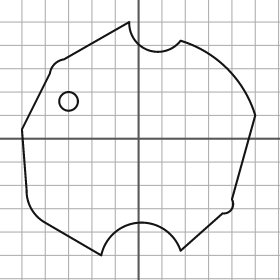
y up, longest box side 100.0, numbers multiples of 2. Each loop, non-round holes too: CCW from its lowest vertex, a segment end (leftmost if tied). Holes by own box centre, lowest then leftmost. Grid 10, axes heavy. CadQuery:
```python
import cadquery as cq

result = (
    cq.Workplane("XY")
    .moveTo(-16.0, -50.0)
    .threePointArc((0.0, -36.0), (18.0, -48.0))
    .lineTo(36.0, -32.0)
    .threePointArc((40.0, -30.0), (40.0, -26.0))
    .lineTo(50.0, 10.0)
    .threePointArc((38.0, 30.0), (18.0, 42.0))
    .threePointArc((4.0, 38.0), (-4.0, 50.0))
    .lineTo(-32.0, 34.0)
    .threePointArc((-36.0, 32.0), (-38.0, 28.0))
    .lineTo(-50.0, 4.0)
    .lineTo(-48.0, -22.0)
    .threePointArc((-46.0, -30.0), (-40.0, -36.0))
    .close()
    .moveTo(-30.0, 16.0)
    .circle(4.0)
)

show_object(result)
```